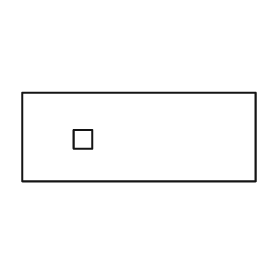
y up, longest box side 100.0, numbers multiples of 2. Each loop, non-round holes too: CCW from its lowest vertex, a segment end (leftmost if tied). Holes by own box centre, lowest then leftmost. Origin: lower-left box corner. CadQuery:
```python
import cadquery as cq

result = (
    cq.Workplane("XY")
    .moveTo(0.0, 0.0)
    .lineTo(100.0, 0.0)
    .lineTo(100.0, 38.0)
    .lineTo(0.0, 38.0)
    .close()
    .moveTo(22.0, 14.0)
    .lineTo(30.0, 14.0)
    .lineTo(30.0, 22.0)
    .lineTo(22.0, 22.0)
    .close()
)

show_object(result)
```